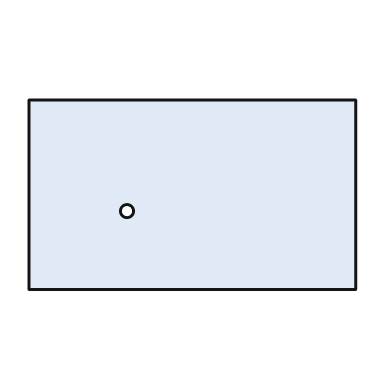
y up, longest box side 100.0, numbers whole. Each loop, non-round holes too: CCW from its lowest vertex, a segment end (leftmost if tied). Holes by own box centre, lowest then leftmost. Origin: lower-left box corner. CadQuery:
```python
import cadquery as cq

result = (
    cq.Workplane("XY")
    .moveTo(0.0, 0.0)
    .lineTo(100.0, 0.0)
    .lineTo(100.0, 58.0)
    .lineTo(0.0, 58.0)
    .close()
    .moveTo(30.0, 24.0)
    .circle(2.0)
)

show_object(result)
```